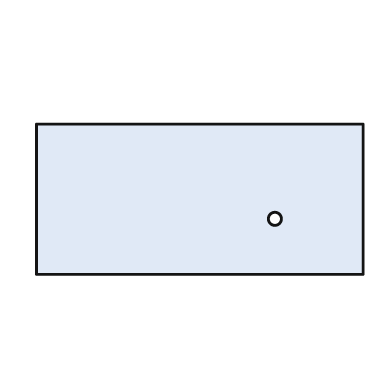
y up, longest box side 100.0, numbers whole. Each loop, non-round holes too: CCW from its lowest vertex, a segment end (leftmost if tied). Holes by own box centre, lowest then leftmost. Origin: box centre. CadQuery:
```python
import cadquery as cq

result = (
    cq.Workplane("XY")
    .moveTo(-50.0, -23.0)
    .lineTo(50.0, -23.0)
    .lineTo(50.0, 23.0)
    .lineTo(-50.0, 23.0)
    .close()
    .moveTo(23.0, -6.0)
    .circle(2.0)
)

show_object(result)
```